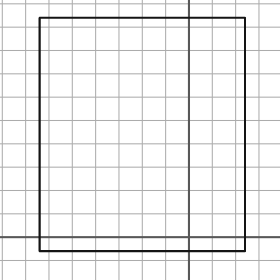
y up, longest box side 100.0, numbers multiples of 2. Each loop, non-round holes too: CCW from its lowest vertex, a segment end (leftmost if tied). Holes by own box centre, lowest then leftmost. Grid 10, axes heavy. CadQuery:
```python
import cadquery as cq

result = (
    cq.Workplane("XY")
    .moveTo(-64.0, -6.0)
    .lineTo(24.0, -6.0)
    .lineTo(24.0, 94.0)
    .lineTo(-64.0, 94.0)
    .close()
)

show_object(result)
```